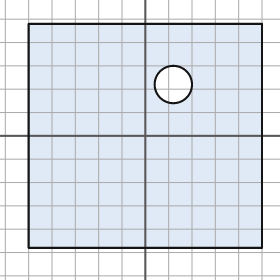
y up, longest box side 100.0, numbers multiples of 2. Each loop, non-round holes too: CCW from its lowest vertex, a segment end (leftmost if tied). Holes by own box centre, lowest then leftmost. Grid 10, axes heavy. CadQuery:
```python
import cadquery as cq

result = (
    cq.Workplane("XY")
    .moveTo(-50.0, -48.0)
    .lineTo(50.0, -48.0)
    .lineTo(50.0, 48.0)
    .lineTo(-50.0, 48.0)
    .close()
    .moveTo(12.0, 22.0)
    .circle(8.0)
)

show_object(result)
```